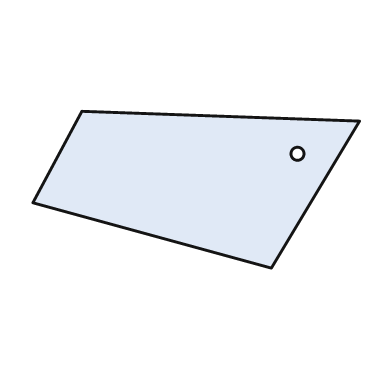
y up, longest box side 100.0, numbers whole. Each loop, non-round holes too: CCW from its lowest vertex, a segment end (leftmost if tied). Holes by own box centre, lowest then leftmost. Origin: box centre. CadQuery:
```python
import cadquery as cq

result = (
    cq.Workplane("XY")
    .moveTo(23.0, -24.0)
    .lineTo(50.0, 21.0)
    .lineTo(-35.0, 24.0)
    .lineTo(-50.0, -4.0)
    .close()
    .moveTo(31.0, 11.0)
    .circle(2.0)
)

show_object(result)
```